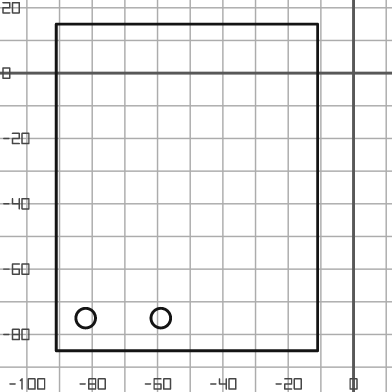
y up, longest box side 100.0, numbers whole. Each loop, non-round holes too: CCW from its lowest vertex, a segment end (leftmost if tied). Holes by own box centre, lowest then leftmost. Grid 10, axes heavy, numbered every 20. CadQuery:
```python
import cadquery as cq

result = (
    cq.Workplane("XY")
    .moveTo(-91.0, -85.0)
    .lineTo(-11.0, -85.0)
    .lineTo(-11.0, 15.0)
    .lineTo(-91.0, 15.0)
    .close()
    .moveTo(-82.0, -75.0)
    .circle(3.0)
    .moveTo(-59.0, -75.0)
    .circle(3.0)
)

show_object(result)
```